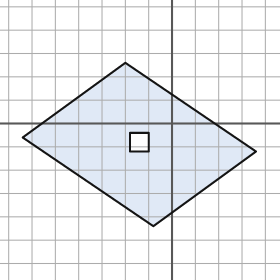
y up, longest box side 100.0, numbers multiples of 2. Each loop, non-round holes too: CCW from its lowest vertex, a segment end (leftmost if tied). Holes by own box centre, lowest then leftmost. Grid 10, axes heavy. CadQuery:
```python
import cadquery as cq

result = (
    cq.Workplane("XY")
    .moveTo(-8.0, -44.0)
    .lineTo(36.0, -12.0)
    .lineTo(-20.0, 26.0)
    .lineTo(-64.0, -6.0)
    .close()
    .moveTo(-18.0, -12.0)
    .lineTo(-10.0, -12.0)
    .lineTo(-10.0, -4.0)
    .lineTo(-18.0, -4.0)
    .close()
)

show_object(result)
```